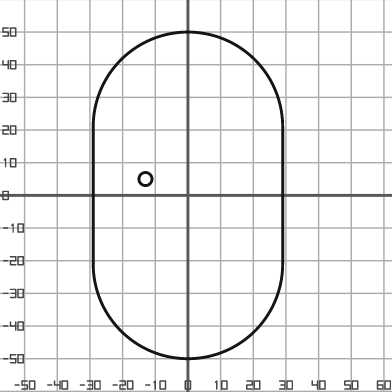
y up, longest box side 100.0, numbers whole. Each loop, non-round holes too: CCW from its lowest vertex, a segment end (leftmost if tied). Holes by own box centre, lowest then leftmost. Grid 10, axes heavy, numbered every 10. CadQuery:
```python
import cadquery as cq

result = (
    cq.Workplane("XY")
    .moveTo(-29.0, -21.0)
    .threePointArc((0.0, -50.0), (29.0, -21.0))
    .lineTo(29.0, 21.0)
    .threePointArc((0.0, 50.0), (-29.0, 21.0))
    .close()
    .moveTo(-13.0, 5.0)
    .circle(2.0)
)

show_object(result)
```